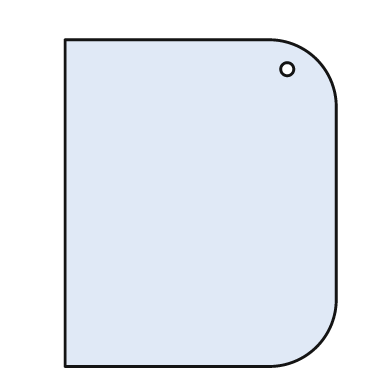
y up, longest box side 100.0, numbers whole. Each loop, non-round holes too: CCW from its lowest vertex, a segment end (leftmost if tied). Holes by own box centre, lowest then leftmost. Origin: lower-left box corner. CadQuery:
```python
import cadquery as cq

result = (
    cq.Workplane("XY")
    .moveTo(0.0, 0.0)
    .lineTo(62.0, 0.0)
    .threePointArc((77.0, 6.0), (83.0, 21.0))
    .lineTo(83.0, 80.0)
    .threePointArc((77.0, 94.0), (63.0, 100.0))
    .lineTo(0.0, 100.0)
    .close()
    .moveTo(68.0, 91.0)
    .circle(2.0)
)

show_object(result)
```